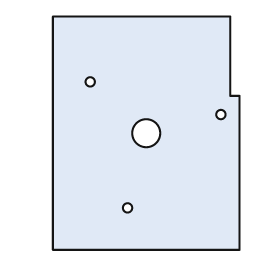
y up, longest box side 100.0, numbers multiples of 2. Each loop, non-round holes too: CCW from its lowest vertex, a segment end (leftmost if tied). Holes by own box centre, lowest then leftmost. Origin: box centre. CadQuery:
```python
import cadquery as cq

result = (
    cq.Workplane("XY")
    .moveTo(-40.0, -50.0)
    .lineTo(40.0, -50.0)
    .lineTo(40.0, 16.0)
    .lineTo(36.0, 16.0)
    .lineTo(36.0, 50.0)
    .lineTo(-40.0, 50.0)
    .close()
    .moveTo(-8.0, -32.0)
    .circle(2.0)
    .moveTo(0.0, 0.0)
    .circle(6.0)
    .moveTo(32.0, 8.0)
    .circle(2.0)
    .moveTo(-24.0, 22.0)
    .circle(2.0)
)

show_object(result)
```